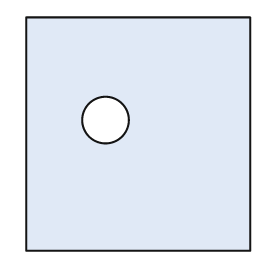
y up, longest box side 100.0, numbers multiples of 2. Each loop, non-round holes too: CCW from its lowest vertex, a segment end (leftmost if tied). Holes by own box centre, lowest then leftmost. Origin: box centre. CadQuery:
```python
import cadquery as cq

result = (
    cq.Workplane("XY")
    .moveTo(-48.0, -50.0)
    .lineTo(48.0, -50.0)
    .lineTo(48.0, 50.0)
    .lineTo(-48.0, 50.0)
    .close()
    .moveTo(-14.0, 6.0)
    .circle(10.0)
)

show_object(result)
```